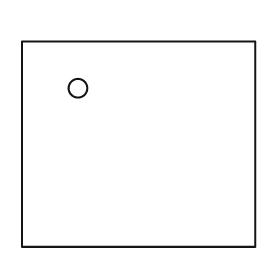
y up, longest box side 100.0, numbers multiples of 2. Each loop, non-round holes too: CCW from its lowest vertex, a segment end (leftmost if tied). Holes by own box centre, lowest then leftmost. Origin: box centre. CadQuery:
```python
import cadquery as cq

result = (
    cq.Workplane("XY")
    .moveTo(-50.0, -44.0)
    .lineTo(50.0, -44.0)
    .lineTo(50.0, 44.0)
    .lineTo(-50.0, 44.0)
    .close()
    .moveTo(-26.0, 24.0)
    .circle(4.0)
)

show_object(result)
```